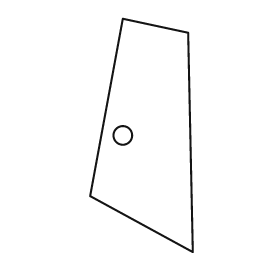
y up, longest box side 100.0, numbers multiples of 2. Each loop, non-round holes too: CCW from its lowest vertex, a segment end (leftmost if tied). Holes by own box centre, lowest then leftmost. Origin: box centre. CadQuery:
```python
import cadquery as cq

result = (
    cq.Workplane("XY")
    .moveTo(22.0, -50.0)
    .lineTo(20.0, 44.0)
    .lineTo(-8.0, 50.0)
    .lineTo(-22.0, -26.0)
    .close()
    .moveTo(-8.0, 0.0)
    .circle(4.0)
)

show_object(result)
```